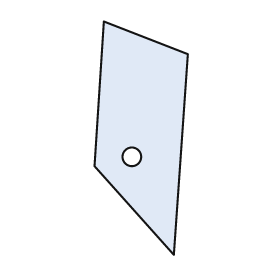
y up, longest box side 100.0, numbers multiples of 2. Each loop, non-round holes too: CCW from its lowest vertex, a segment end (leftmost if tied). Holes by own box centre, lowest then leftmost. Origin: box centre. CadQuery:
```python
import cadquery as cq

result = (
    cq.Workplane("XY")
    .moveTo(14.0, -50.0)
    .lineTo(20.0, 36.0)
    .lineTo(-16.0, 50.0)
    .lineTo(-20.0, -12.0)
    .close()
    .moveTo(-4.0, -8.0)
    .circle(4.0)
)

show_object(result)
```